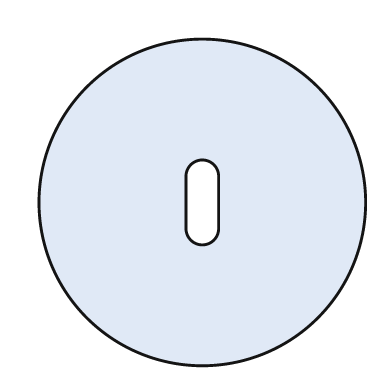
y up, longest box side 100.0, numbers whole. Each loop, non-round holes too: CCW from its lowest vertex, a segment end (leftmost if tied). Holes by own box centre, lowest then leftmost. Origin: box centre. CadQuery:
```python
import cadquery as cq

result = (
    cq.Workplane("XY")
    .moveTo(0.0, 0.0)
    .circle(50.0)
    .moveTo(-5.0, -8.0)
    .threePointArc((0.0, -13.0), (5.0, -8.0))
    .lineTo(5.0, 8.0)
    .threePointArc((0.0, 13.0), (-5.0, 8.0))
    .close()
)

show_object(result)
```